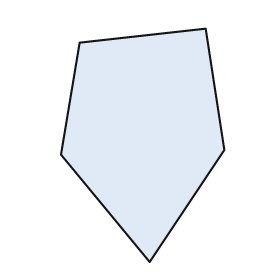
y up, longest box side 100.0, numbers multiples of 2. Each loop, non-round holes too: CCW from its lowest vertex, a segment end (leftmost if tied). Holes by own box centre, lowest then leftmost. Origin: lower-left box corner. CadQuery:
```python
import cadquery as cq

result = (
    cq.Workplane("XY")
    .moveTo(38.0, 0.0)
    .lineTo(70.0, 48.0)
    .lineTo(62.0, 100.0)
    .lineTo(8.0, 94.0)
    .lineTo(0.0, 46.0)
    .close()
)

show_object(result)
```